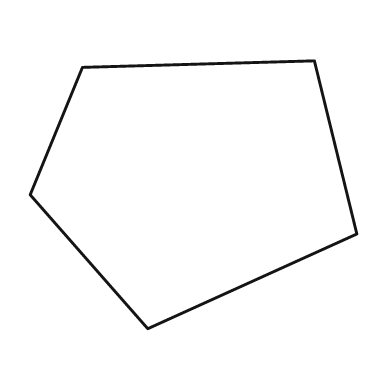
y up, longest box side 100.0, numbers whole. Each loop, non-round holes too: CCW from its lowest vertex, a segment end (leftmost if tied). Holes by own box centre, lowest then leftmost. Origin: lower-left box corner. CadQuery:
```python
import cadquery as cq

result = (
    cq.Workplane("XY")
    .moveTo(36.0, 0.0)
    .lineTo(100.0, 29.0)
    .lineTo(87.0, 82.0)
    .lineTo(16.0, 80.0)
    .lineTo(0.0, 41.0)
    .close()
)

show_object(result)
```